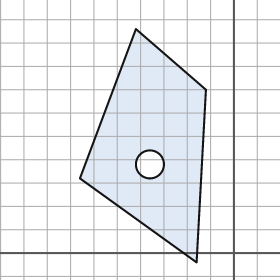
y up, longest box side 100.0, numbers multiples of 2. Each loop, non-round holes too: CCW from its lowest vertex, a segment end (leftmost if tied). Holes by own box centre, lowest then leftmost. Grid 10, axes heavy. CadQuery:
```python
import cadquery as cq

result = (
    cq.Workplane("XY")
    .moveTo(-16.0, -4.0)
    .lineTo(-12.0, 70.0)
    .lineTo(-42.0, 96.0)
    .lineTo(-66.0, 32.0)
    .close()
    .moveTo(-36.0, 38.0)
    .circle(6.0)
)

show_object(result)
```